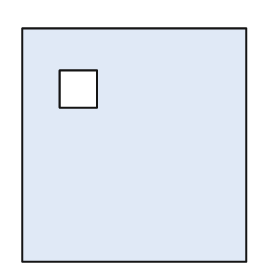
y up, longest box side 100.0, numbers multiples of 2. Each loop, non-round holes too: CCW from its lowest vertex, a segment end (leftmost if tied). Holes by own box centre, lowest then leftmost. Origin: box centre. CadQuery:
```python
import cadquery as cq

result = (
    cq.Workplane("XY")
    .moveTo(-48.0, -50.0)
    .lineTo(48.0, -50.0)
    .lineTo(48.0, 50.0)
    .lineTo(-48.0, 50.0)
    .close()
    .moveTo(-32.0, 16.0)
    .lineTo(-16.0, 16.0)
    .lineTo(-16.0, 32.0)
    .lineTo(-32.0, 32.0)
    .close()
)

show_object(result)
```